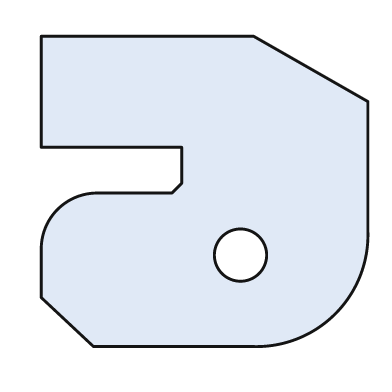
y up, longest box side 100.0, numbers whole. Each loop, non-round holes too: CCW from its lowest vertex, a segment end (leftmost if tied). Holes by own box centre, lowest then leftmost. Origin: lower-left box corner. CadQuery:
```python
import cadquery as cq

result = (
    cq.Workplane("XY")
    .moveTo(16.0, 0.0)
    .lineTo(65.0, 0.0)
    .threePointArc((90.0, 10.0), (100.0, 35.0))
    .lineTo(100.0, 75.0)
    .lineTo(65.0, 95.0)
    .lineTo(0.0, 95.0)
    .lineTo(0.0, 61.0)
    .lineTo(43.0, 61.0)
    .lineTo(43.0, 50.0)
    .lineTo(40.0, 47.0)
    .lineTo(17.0, 47.0)
    .threePointArc((5.0, 42.0), (0.0, 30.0))
    .lineTo(0.0, 15.0)
    .close()
    .moveTo(61.0, 28.0)
    .circle(8.0)
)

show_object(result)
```